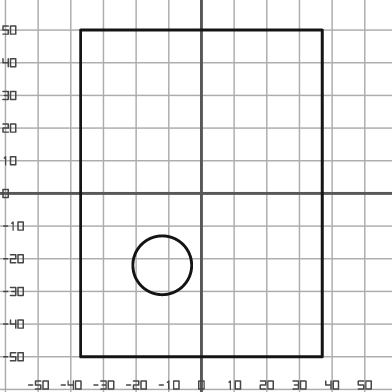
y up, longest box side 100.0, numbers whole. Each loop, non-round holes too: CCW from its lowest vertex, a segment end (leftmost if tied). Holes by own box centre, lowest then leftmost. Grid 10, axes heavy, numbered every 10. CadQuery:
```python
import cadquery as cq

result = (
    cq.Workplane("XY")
    .moveTo(-37.0, -50.0)
    .lineTo(37.0, -50.0)
    .lineTo(37.0, 50.0)
    .lineTo(-37.0, 50.0)
    .close()
    .moveTo(-12.0, -22.0)
    .circle(9.0)
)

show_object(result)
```